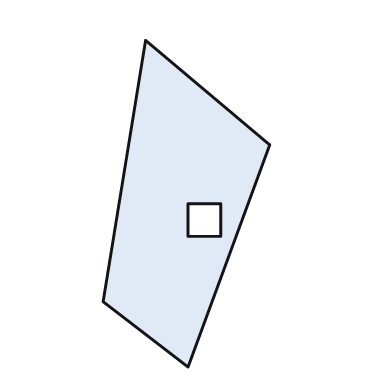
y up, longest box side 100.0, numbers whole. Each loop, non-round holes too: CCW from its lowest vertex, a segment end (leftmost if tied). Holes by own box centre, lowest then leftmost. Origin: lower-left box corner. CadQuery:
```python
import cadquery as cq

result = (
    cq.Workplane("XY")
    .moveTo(26.0, 0.0)
    .lineTo(51.0, 68.0)
    .lineTo(13.0, 100.0)
    .lineTo(0.0, 20.0)
    .close()
    .moveTo(26.0, 40.0)
    .lineTo(36.0, 40.0)
    .lineTo(36.0, 50.0)
    .lineTo(26.0, 50.0)
    .close()
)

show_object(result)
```